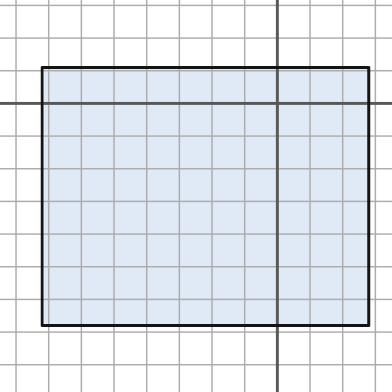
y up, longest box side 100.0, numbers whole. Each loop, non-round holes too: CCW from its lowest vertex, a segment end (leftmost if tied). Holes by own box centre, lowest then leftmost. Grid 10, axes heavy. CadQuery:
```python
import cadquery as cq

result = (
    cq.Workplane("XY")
    .moveTo(-72.0, -68.0)
    .lineTo(28.0, -68.0)
    .lineTo(28.0, 11.0)
    .lineTo(-72.0, 11.0)
    .close()
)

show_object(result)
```